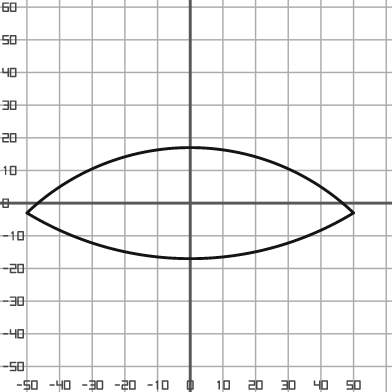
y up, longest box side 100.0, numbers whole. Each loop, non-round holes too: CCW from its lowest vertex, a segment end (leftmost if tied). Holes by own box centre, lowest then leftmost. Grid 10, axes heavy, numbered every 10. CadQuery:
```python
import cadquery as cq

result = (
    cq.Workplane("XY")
    .moveTo(-50.0, -3.0)
    .threePointArc((0.0, -17.0), (50.0, -3.0))
    .threePointArc((0.0, 17.0), (-50.0, -3.0))
    .close()
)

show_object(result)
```